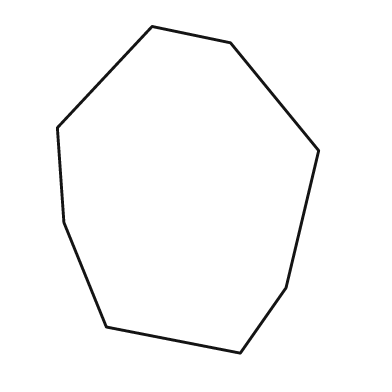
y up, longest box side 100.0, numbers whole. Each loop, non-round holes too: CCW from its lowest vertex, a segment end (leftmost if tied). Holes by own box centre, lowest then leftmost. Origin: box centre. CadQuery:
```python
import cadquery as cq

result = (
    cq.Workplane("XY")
    .moveTo(16.0, -50.0)
    .lineTo(30.0, -30.0)
    .lineTo(40.0, 12.0)
    .lineTo(13.0, 45.0)
    .lineTo(-11.0, 50.0)
    .lineTo(-40.0, 19.0)
    .lineTo(-38.0, -10.0)
    .lineTo(-25.0, -42.0)
    .close()
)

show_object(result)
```